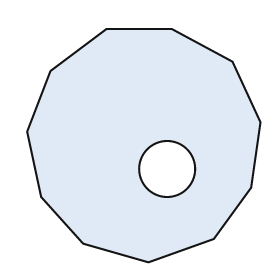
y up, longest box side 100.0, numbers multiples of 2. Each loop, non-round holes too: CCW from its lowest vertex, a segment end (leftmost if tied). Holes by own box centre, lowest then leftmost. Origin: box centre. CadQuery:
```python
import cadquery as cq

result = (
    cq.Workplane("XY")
    .moveTo(2.0, -50.0)
    .lineTo(30.0, -40.0)
    .lineTo(46.0, -18.0)
    .lineTo(50.0, 10.0)
    .lineTo(38.0, 36.0)
    .lineTo(12.0, 50.0)
    .lineTo(-16.0, 50.0)
    .lineTo(-40.0, 32.0)
    .lineTo(-50.0, 6.0)
    .lineTo(-44.0, -22.0)
    .lineTo(-26.0, -42.0)
    .close()
    .moveTo(10.0, -10.0)
    .circle(12.0)
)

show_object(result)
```